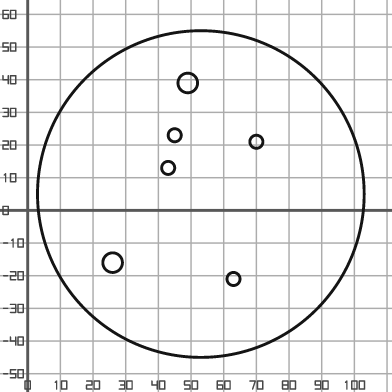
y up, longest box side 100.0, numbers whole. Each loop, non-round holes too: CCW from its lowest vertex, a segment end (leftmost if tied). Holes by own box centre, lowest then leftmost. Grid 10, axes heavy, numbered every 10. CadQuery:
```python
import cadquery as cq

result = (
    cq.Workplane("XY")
    .moveTo(53.0, 5.0)
    .circle(50.0)
    .moveTo(63.0, -21.0)
    .circle(2.0)
    .moveTo(26.0, -16.0)
    .circle(3.0)
    .moveTo(43.0, 13.0)
    .circle(2.0)
    .moveTo(70.0, 21.0)
    .circle(2.0)
    .moveTo(45.0, 23.0)
    .circle(2.0)
    .moveTo(49.0, 39.0)
    .circle(3.0)
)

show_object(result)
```